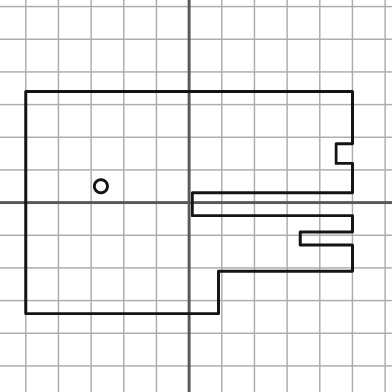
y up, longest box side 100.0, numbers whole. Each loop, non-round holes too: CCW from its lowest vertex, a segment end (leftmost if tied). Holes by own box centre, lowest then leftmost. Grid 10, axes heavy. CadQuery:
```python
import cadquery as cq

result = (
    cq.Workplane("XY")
    .moveTo(-50.0, -34.0)
    .lineTo(9.0, -34.0)
    .lineTo(9.0, -21.0)
    .lineTo(50.0, -21.0)
    .lineTo(50.0, -13.0)
    .lineTo(34.0, -13.0)
    .lineTo(34.0, -9.0)
    .lineTo(50.0, -9.0)
    .lineTo(50.0, -4.0)
    .lineTo(1.0, -4.0)
    .lineTo(1.0, 3.0)
    .lineTo(50.0, 3.0)
    .lineTo(50.0, 12.0)
    .lineTo(45.0, 12.0)
    .lineTo(45.0, 18.0)
    .lineTo(50.0, 18.0)
    .lineTo(50.0, 34.0)
    .lineTo(-50.0, 34.0)
    .close()
    .moveTo(-27.0, 5.0)
    .circle(2.0)
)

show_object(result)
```